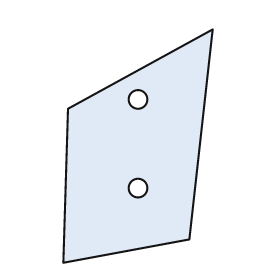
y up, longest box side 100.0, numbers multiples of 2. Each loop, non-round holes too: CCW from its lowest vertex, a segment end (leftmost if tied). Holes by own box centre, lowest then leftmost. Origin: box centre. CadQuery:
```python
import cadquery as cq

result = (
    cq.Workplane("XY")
    .moveTo(-32.0, -50.0)
    .lineTo(22.0, -40.0)
    .lineTo(32.0, 50.0)
    .lineTo(-30.0, 16.0)
    .close()
    .moveTo(0.0, -18.0)
    .circle(4.0)
    .moveTo(0.0, 20.0)
    .circle(4.0)
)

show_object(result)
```